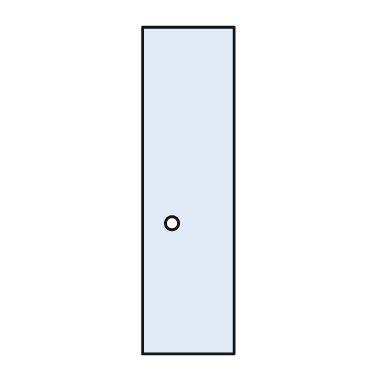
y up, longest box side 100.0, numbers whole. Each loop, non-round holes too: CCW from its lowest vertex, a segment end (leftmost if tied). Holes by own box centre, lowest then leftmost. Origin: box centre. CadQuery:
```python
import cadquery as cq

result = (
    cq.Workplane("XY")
    .moveTo(-14.0, -50.0)
    .lineTo(14.0, -50.0)
    .lineTo(14.0, 50.0)
    .lineTo(-14.0, 50.0)
    .close()
    .moveTo(-5.0, -10.0)
    .circle(2.0)
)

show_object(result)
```